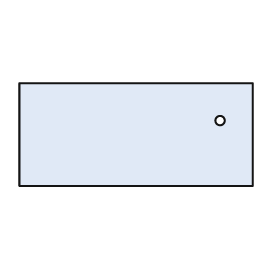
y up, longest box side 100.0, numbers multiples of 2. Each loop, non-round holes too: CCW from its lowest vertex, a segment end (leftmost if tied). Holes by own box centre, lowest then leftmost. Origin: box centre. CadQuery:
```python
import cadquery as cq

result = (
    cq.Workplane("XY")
    .moveTo(-50.0, -22.0)
    .lineTo(50.0, -22.0)
    .lineTo(50.0, 22.0)
    .lineTo(-50.0, 22.0)
    .close()
    .moveTo(36.0, 6.0)
    .circle(2.0)
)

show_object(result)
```